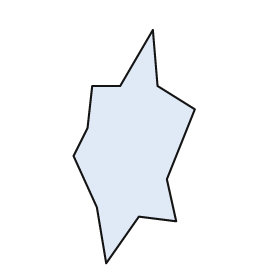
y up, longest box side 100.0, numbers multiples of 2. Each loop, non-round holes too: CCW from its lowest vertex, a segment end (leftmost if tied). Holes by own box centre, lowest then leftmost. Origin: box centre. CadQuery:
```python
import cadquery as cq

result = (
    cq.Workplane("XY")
    .moveTo(-12.0, -50.0)
    .lineTo(2.0, -30.0)
    .lineTo(18.0, -32.0)
    .lineTo(14.0, -14.0)
    .lineTo(26.0, 16.0)
    .lineTo(10.0, 26.0)
    .lineTo(8.0, 50.0)
    .lineTo(-6.0, 26.0)
    .lineTo(-18.0, 26.0)
    .lineTo(-20.0, 8.0)
    .lineTo(-26.0, -4.0)
    .lineTo(-16.0, -26.0)
    .close()
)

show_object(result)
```